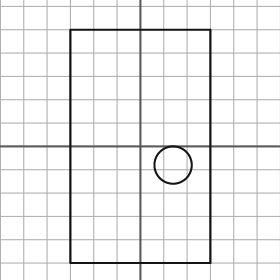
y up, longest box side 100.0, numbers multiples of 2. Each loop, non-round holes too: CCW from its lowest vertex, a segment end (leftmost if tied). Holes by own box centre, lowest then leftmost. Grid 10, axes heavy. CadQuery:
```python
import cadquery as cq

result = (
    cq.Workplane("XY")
    .moveTo(-30.0, -50.0)
    .lineTo(30.0, -50.0)
    .lineTo(30.0, 50.0)
    .lineTo(-30.0, 50.0)
    .close()
    .moveTo(14.0, -8.0)
    .circle(8.0)
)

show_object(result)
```